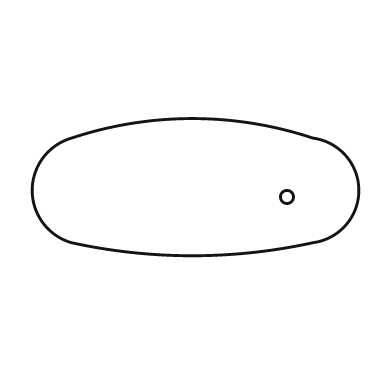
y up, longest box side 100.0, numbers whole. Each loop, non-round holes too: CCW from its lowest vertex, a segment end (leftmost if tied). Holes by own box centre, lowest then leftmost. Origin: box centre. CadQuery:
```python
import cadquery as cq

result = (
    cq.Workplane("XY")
    .moveTo(-38.0, -17.0)
    .threePointArc((-1.0, -21.0), (36.0, -17.0))
    .threePointArc((50.0, -1.0), (36.0, 15.0))
    .threePointArc((-1.0, 21.0), (-38.0, 15.0))
    .threePointArc((-50.0, -1.0), (-38.0, -17.0))
    .close()
    .moveTo(28.0, -3.0)
    .circle(2.0)
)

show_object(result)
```